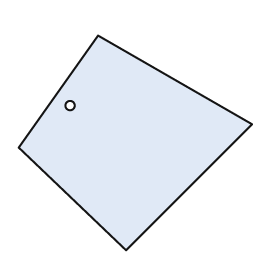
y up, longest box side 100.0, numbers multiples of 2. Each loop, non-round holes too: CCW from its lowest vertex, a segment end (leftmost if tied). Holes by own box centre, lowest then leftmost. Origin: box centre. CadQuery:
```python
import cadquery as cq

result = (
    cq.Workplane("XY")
    .moveTo(-4.0, -46.0)
    .lineTo(50.0, 8.0)
    .lineTo(-16.0, 46.0)
    .lineTo(-50.0, -2.0)
    .close()
    .moveTo(-28.0, 16.0)
    .circle(2.0)
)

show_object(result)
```